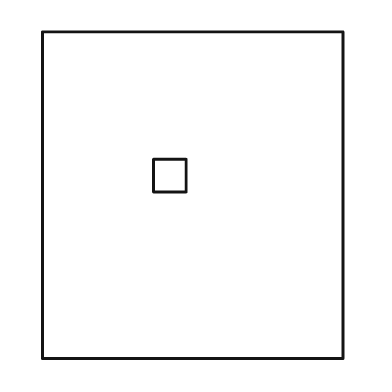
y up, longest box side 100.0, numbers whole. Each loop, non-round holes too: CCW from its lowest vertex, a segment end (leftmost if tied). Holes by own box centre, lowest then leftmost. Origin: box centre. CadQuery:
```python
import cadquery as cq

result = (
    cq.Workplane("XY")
    .moveTo(-46.0, -50.0)
    .lineTo(46.0, -50.0)
    .lineTo(46.0, 50.0)
    .lineTo(-46.0, 50.0)
    .close()
    .moveTo(-12.0, 1.0)
    .lineTo(-2.0, 1.0)
    .lineTo(-2.0, 11.0)
    .lineTo(-12.0, 11.0)
    .close()
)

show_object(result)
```